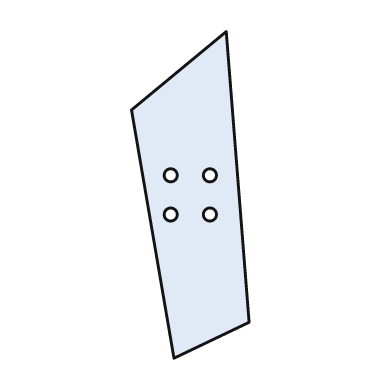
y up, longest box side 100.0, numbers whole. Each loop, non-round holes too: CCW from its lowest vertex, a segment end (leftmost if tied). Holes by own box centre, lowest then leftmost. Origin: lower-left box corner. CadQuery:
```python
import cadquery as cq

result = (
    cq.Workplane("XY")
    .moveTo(13.0, 0.0)
    .lineTo(36.0, 11.0)
    .lineTo(29.0, 100.0)
    .lineTo(0.0, 76.0)
    .close()
    .moveTo(12.0, 44.0)
    .circle(2.0)
    .moveTo(24.0, 44.0)
    .circle(2.0)
    .moveTo(12.0, 56.0)
    .circle(2.0)
    .moveTo(24.0, 56.0)
    .circle(2.0)
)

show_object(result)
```